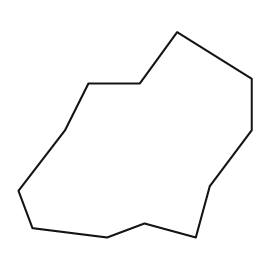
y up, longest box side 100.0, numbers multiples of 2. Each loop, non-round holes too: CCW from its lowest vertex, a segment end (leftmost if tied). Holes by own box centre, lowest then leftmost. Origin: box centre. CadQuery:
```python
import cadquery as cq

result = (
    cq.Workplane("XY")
    .moveTo(-12.0, -44.0)
    .lineTo(4.0, -38.0)
    .lineTo(26.0, -44.0)
    .lineTo(32.0, -22.0)
    .lineTo(50.0, 2.0)
    .lineTo(50.0, 24.0)
    .lineTo(18.0, 44.0)
    .lineTo(2.0, 22.0)
    .lineTo(-20.0, 22.0)
    .lineTo(-30.0, 2.0)
    .lineTo(-50.0, -24.0)
    .lineTo(-44.0, -40.0)
    .close()
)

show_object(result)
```